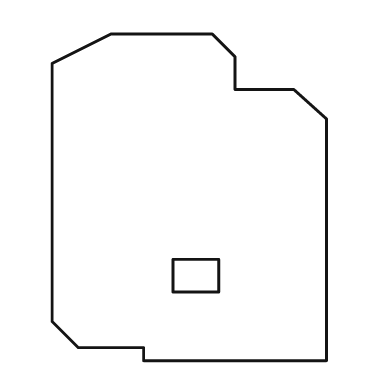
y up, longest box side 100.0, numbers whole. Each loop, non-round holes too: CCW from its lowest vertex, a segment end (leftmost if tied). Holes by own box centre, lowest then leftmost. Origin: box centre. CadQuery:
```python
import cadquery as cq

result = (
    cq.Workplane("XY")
    .moveTo(-14.0, -50.0)
    .lineTo(42.0, -50.0)
    .lineTo(42.0, 24.0)
    .lineTo(32.0, 33.0)
    .lineTo(14.0, 33.0)
    .lineTo(14.0, 43.0)
    .lineTo(7.0, 50.0)
    .lineTo(-24.0, 50.0)
    .lineTo(-42.0, 41.0)
    .lineTo(-42.0, -38.0)
    .lineTo(-34.0, -46.0)
    .lineTo(-14.0, -46.0)
    .close()
    .moveTo(-5.0, -29.0)
    .lineTo(9.0, -29.0)
    .lineTo(9.0, -19.0)
    .lineTo(-5.0, -19.0)
    .close()
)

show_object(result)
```